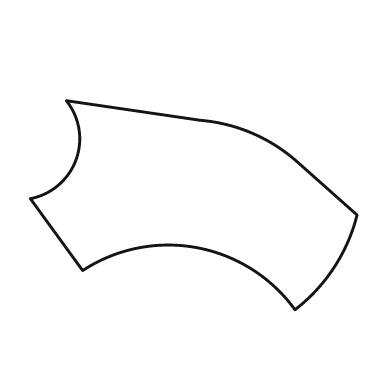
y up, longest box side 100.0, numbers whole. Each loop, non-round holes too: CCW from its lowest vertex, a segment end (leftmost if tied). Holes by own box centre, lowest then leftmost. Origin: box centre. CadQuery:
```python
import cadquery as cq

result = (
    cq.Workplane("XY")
    .moveTo(31.0, -32.0)
    .threePointArc((43.0, -19.0), (50.0, -3.0))
    .lineTo(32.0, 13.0)
    .threePointArc((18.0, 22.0), (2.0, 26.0))
    .lineTo(-39.0, 32.0)
    .threePointArc((-36.0, 14.0), (-50.0, 2.0))
    .lineTo(-34.0, -20.0)
    .threePointArc((1.0, -13.0), (31.0, -32.0))
    .close()
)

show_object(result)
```